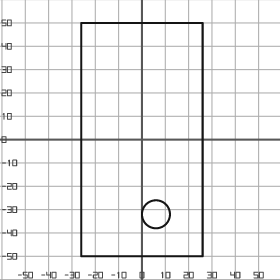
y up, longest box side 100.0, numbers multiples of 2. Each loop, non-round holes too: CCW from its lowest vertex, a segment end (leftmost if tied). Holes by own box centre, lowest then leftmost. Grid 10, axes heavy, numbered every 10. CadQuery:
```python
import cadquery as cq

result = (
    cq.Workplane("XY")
    .moveTo(-26.0, -50.0)
    .lineTo(26.0, -50.0)
    .lineTo(26.0, 50.0)
    .lineTo(-26.0, 50.0)
    .close()
    .moveTo(6.0, -32.0)
    .circle(6.0)
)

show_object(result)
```